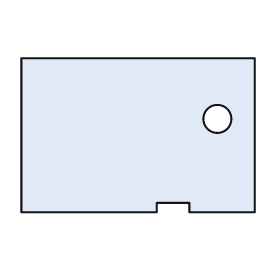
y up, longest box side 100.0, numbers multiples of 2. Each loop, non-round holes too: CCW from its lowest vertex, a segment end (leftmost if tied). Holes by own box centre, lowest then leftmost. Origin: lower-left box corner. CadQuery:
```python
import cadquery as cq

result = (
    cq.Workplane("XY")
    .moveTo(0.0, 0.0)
    .lineTo(58.0, 0.0)
    .lineTo(58.0, 4.0)
    .lineTo(72.0, 4.0)
    .lineTo(72.0, 0.0)
    .lineTo(100.0, 0.0)
    .lineTo(100.0, 66.0)
    .lineTo(0.0, 66.0)
    .close()
    .moveTo(84.0, 40.0)
    .circle(6.0)
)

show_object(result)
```